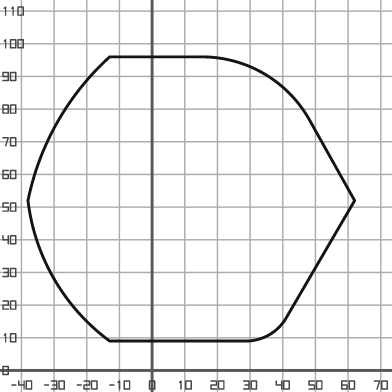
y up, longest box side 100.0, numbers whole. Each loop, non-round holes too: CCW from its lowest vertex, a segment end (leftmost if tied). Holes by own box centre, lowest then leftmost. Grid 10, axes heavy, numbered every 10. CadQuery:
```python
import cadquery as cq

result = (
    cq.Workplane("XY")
    .moveTo(-13.0, 9.0)
    .lineTo(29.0, 9.0)
    .threePointArc((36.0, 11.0), (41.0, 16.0))
    .lineTo(62.0, 52.0)
    .lineTo(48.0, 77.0)
    .threePointArc((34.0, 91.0), (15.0, 96.0))
    .lineTo(-13.0, 96.0)
    .threePointArc((-29.0, 76.0), (-38.0, 52.0))
    .threePointArc((-30.0, 28.0), (-13.0, 9.0))
    .close()
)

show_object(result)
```